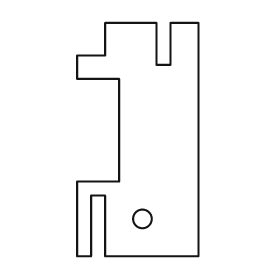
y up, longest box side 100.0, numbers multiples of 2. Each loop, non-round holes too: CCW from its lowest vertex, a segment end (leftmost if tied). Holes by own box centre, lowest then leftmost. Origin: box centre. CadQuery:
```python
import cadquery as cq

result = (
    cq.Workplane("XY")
    .moveTo(-26.0, -50.0)
    .lineTo(-20.0, -50.0)
    .lineTo(-20.0, -24.0)
    .lineTo(-14.0, -24.0)
    .lineTo(-14.0, -50.0)
    .lineTo(26.0, -50.0)
    .lineTo(26.0, 50.0)
    .lineTo(14.0, 50.0)
    .lineTo(14.0, 32.0)
    .lineTo(8.0, 32.0)
    .lineTo(8.0, 50.0)
    .lineTo(-14.0, 50.0)
    .lineTo(-14.0, 36.0)
    .lineTo(-26.0, 36.0)
    .lineTo(-26.0, 26.0)
    .lineTo(-8.0, 26.0)
    .lineTo(-8.0, -18.0)
    .lineTo(-26.0, -18.0)
    .close()
    .moveTo(2.0, -34.0)
    .circle(4.0)
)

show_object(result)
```